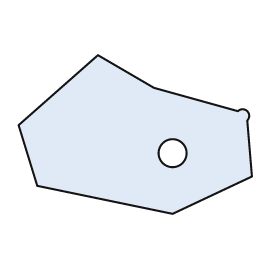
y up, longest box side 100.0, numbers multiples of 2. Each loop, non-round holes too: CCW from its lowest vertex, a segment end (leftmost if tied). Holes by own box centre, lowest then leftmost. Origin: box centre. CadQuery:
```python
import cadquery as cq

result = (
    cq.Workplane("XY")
    .moveTo(16.0, -34.0)
    .lineTo(50.0, -18.0)
    .lineTo(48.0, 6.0)
    .threePointArc((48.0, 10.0), (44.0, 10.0))
    .lineTo(8.0, 20.0)
    .lineTo(-16.0, 34.0)
    .lineTo(-50.0, 4.0)
    .lineTo(-42.0, -22.0)
    .close()
    .moveTo(16.0, -8.0)
    .circle(6.0)
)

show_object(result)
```